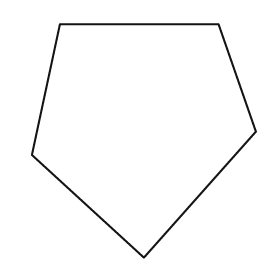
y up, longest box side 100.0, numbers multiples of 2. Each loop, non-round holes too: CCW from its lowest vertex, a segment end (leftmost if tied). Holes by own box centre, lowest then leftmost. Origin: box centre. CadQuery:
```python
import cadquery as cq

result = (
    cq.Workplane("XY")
    .moveTo(0.0, -50.0)
    .lineTo(48.0, 4.0)
    .lineTo(32.0, 50.0)
    .lineTo(-36.0, 50.0)
    .lineTo(-48.0, -6.0)
    .close()
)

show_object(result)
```